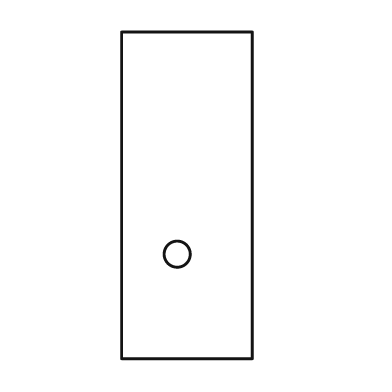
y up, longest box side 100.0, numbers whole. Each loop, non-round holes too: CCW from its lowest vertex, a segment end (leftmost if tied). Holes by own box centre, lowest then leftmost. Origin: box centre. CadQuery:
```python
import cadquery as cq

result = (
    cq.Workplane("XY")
    .moveTo(-20.0, -50.0)
    .lineTo(20.0, -50.0)
    .lineTo(20.0, 50.0)
    .lineTo(-20.0, 50.0)
    .close()
    .moveTo(-3.0, -18.0)
    .circle(4.0)
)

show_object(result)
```